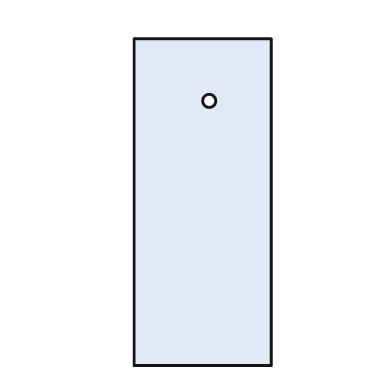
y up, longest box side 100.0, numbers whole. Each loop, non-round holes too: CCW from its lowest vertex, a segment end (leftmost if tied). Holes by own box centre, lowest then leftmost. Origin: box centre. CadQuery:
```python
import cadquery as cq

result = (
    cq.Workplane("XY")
    .moveTo(-21.0, -50.0)
    .lineTo(21.0, -50.0)
    .lineTo(21.0, 50.0)
    .lineTo(-21.0, 50.0)
    .close()
    .moveTo(2.0, 31.0)
    .circle(2.0)
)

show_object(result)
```